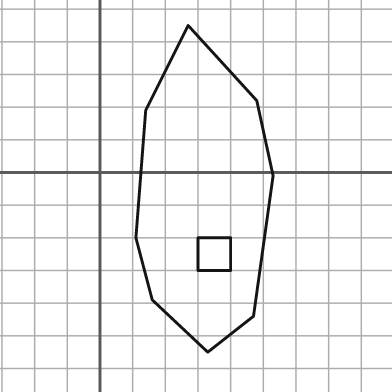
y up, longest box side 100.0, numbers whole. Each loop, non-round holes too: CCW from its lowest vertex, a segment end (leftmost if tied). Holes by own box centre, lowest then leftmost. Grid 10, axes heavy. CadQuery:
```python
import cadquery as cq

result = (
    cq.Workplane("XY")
    .moveTo(33.0, -55.0)
    .lineTo(47.0, -44.0)
    .lineTo(53.0, -1.0)
    .lineTo(48.0, 22.0)
    .lineTo(27.0, 45.0)
    .lineTo(14.0, 19.0)
    .lineTo(11.0, -20.0)
    .lineTo(16.0, -39.0)
    .close()
    .moveTo(30.0, -30.0)
    .lineTo(40.0, -30.0)
    .lineTo(40.0, -20.0)
    .lineTo(30.0, -20.0)
    .close()
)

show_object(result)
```